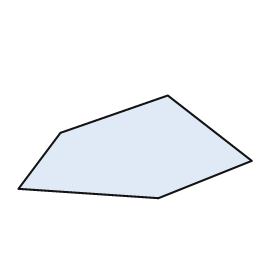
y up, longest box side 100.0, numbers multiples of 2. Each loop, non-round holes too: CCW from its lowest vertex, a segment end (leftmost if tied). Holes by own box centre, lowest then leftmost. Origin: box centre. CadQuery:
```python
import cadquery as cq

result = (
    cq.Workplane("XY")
    .moveTo(10.0, -22.0)
    .lineTo(50.0, -6.0)
    .lineTo(14.0, 22.0)
    .lineTo(-32.0, 6.0)
    .lineTo(-50.0, -18.0)
    .close()
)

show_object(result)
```